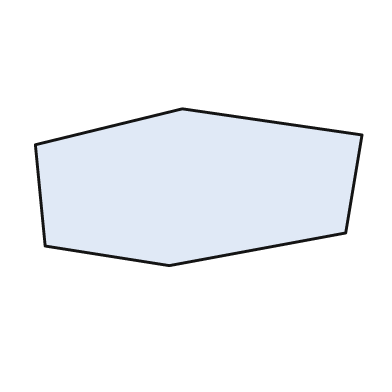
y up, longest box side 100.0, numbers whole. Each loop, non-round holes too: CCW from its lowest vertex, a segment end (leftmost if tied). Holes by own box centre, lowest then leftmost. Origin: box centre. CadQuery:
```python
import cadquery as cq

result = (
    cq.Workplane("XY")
    .moveTo(-9.0, -24.0)
    .lineTo(45.0, -14.0)
    .lineTo(50.0, 16.0)
    .lineTo(-5.0, 24.0)
    .lineTo(-50.0, 13.0)
    .lineTo(-47.0, -18.0)
    .close()
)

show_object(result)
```